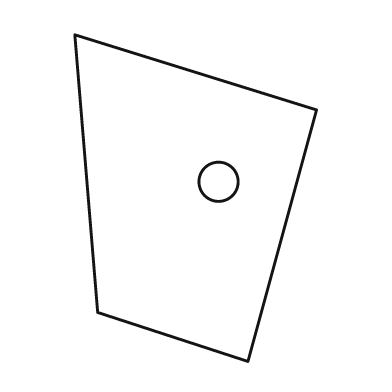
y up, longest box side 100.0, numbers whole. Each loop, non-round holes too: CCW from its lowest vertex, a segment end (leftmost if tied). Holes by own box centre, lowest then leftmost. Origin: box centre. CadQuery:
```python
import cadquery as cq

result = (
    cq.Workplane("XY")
    .moveTo(16.0, -50.0)
    .lineTo(37.0, 27.0)
    .lineTo(-37.0, 50.0)
    .lineTo(-30.0, -35.0)
    .close()
    .moveTo(7.0, 5.0)
    .circle(6.0)
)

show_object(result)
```